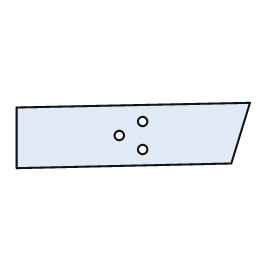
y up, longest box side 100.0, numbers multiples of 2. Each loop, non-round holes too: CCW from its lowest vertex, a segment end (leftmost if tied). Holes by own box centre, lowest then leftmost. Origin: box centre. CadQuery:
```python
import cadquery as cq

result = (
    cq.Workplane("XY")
    .moveTo(-50.0, -14.0)
    .lineTo(42.0, -12.0)
    .lineTo(50.0, 14.0)
    .lineTo(-50.0, 12.0)
    .close()
    .moveTo(4.0, -6.0)
    .circle(2.0)
    .moveTo(-6.0, 0.0)
    .circle(2.0)
    .moveTo(4.0, 6.0)
    .circle(2.0)
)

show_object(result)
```